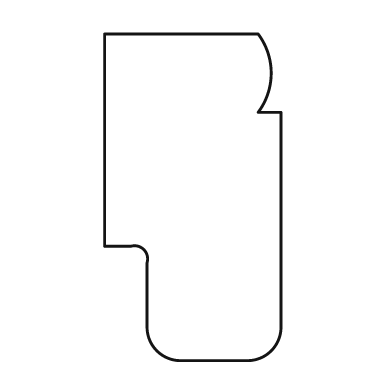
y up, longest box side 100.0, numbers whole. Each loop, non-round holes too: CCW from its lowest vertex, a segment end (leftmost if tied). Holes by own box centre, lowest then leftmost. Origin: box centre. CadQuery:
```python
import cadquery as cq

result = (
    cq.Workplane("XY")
    .moveTo(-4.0, -50.0)
    .lineTo(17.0, -50.0)
    .threePointArc((24.0, -47.0), (27.0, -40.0))
    .lineTo(27.0, 26.0)
    .lineTo(20.0, 26.0)
    .threePointArc((24.0, 38.0), (20.0, 50.0))
    .lineTo(-27.0, 50.0)
    .lineTo(-27.0, -15.0)
    .lineTo(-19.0, -15.0)
    .threePointArc((-15.0, -16.0), (-14.0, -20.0))
    .lineTo(-14.0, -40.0)
    .threePointArc((-11.0, -47.0), (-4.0, -50.0))
    .close()
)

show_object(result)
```